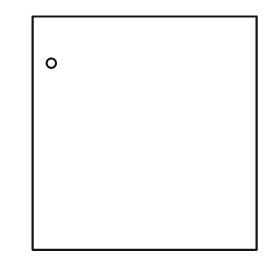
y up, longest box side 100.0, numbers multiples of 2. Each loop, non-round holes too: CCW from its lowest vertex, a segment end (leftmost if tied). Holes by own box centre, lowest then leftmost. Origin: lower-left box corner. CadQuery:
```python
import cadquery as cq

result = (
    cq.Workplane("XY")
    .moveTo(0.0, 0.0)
    .lineTo(96.0, 0.0)
    .lineTo(96.0, 100.0)
    .lineTo(0.0, 100.0)
    .close()
    .moveTo(8.0, 80.0)
    .circle(2.0)
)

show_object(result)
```